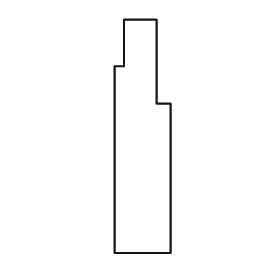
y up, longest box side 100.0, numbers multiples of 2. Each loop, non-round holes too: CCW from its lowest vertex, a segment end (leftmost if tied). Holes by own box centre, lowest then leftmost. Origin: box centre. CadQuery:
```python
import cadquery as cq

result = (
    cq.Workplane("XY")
    .moveTo(-12.0, -50.0)
    .lineTo(12.0, -50.0)
    .lineTo(12.0, 14.0)
    .lineTo(6.0, 14.0)
    .lineTo(6.0, 50.0)
    .lineTo(-8.0, 50.0)
    .lineTo(-8.0, 30.0)
    .lineTo(-12.0, 30.0)
    .close()
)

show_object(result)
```